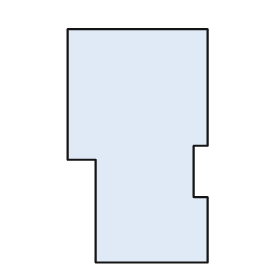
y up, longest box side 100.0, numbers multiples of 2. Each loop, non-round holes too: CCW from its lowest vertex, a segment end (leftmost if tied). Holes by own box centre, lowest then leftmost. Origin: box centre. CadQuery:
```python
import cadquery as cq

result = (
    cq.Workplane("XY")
    .moveTo(-18.0, -50.0)
    .lineTo(30.0, -50.0)
    .lineTo(30.0, -22.0)
    .lineTo(24.0, -22.0)
    .lineTo(24.0, 0.0)
    .lineTo(30.0, 0.0)
    .lineTo(30.0, 50.0)
    .lineTo(-30.0, 50.0)
    .lineTo(-30.0, -6.0)
    .lineTo(-18.0, -6.0)
    .close()
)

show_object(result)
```